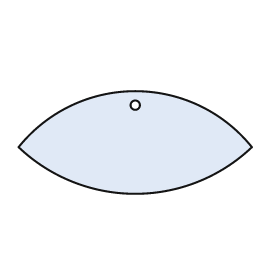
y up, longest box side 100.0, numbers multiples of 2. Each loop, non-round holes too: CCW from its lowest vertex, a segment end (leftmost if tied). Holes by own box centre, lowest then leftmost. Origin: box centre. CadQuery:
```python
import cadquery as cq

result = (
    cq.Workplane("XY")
    .moveTo(-50.0, -2.0)
    .threePointArc((0.0, -22.0), (50.0, -2.0))
    .threePointArc((0.0, 22.0), (-50.0, -2.0))
    .close()
    .moveTo(0.0, 16.0)
    .circle(2.0)
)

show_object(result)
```